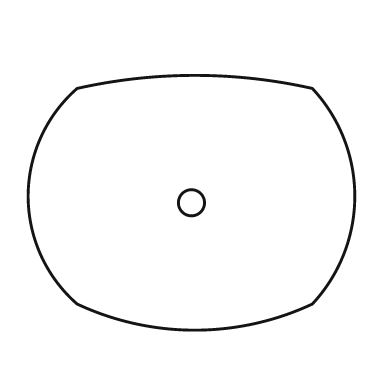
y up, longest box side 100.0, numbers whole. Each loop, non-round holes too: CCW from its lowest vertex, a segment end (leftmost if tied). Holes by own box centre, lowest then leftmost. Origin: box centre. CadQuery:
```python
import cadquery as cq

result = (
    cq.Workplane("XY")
    .moveTo(-35.0, -31.0)
    .threePointArc((1.0, -39.0), (37.0, -31.0))
    .threePointArc((50.0, 2.0), (37.0, 35.0))
    .threePointArc((1.0, 39.0), (-35.0, 35.0))
    .threePointArc((-50.0, 2.0), (-35.0, -31.0))
    .close()
    .moveTo(0.0, 0.0)
    .circle(4.0)
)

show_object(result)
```